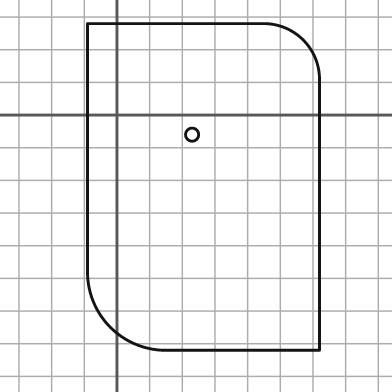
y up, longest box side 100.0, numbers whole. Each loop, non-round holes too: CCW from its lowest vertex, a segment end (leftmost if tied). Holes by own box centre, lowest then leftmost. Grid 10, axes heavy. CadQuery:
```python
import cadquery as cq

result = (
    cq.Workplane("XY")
    .moveTo(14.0, -72.0)
    .lineTo(62.0, -72.0)
    .lineTo(62.0, 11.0)
    .threePointArc((57.0, 23.0), (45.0, 28.0))
    .lineTo(-9.0, 28.0)
    .lineTo(-9.0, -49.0)
    .threePointArc((-2.0, -65.0), (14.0, -72.0))
    .close()
    .moveTo(23.0, -6.0)
    .circle(2.0)
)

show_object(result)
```